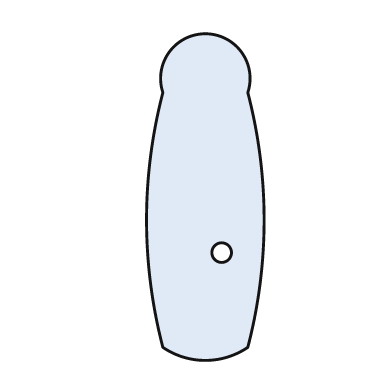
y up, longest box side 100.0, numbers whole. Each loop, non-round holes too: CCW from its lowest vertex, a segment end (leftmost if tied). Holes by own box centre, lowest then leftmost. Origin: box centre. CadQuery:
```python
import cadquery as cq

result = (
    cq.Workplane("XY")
    .moveTo(-13.0, -46.0)
    .threePointArc((0.0, -50.0), (13.0, -46.0))
    .threePointArc((18.0, -7.0), (13.0, 32.0))
    .threePointArc((0.0, 50.0), (-13.0, 32.0))
    .threePointArc((-18.0, -7.0), (-13.0, -46.0))
    .close()
    .moveTo(5.0, -17.0)
    .circle(3.0)
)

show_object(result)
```